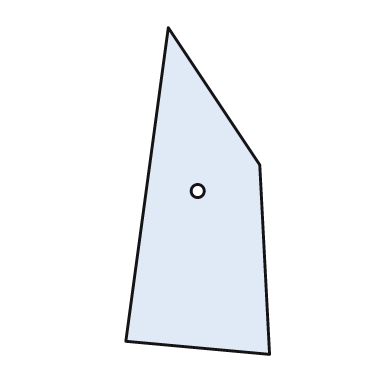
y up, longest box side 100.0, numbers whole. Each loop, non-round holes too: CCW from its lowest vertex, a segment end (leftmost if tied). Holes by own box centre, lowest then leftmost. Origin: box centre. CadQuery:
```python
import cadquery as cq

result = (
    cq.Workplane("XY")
    .moveTo(22.0, -50.0)
    .lineTo(19.0, 8.0)
    .lineTo(-9.0, 50.0)
    .lineTo(-22.0, -46.0)
    .close()
    .moveTo(0.0, 0.0)
    .circle(2.0)
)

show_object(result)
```